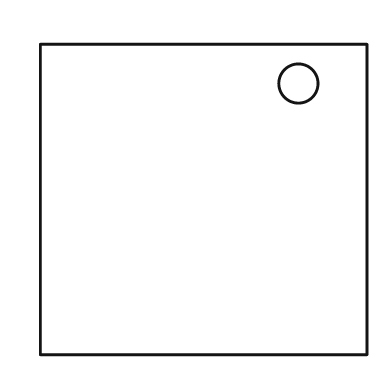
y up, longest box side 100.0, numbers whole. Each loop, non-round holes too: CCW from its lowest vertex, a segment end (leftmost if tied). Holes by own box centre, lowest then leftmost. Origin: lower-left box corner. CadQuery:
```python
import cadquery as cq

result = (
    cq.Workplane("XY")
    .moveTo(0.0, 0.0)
    .lineTo(100.0, 0.0)
    .lineTo(100.0, 95.0)
    .lineTo(0.0, 95.0)
    .close()
    .moveTo(79.0, 83.0)
    .circle(6.0)
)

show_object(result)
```